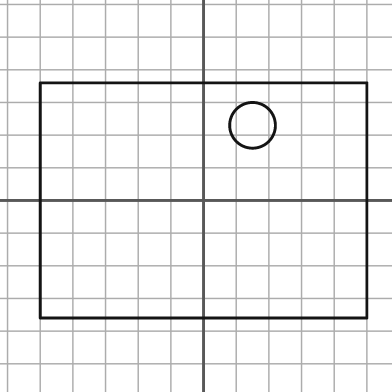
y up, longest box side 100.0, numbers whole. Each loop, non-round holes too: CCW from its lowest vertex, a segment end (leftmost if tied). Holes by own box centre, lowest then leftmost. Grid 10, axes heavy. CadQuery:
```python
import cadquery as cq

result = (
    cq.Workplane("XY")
    .moveTo(-50.0, -36.0)
    .lineTo(50.0, -36.0)
    .lineTo(50.0, 36.0)
    .lineTo(-50.0, 36.0)
    .close()
    .moveTo(15.0, 23.0)
    .circle(7.0)
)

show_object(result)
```